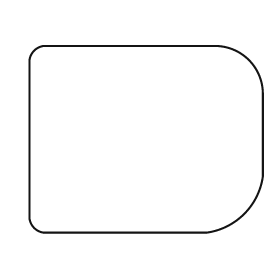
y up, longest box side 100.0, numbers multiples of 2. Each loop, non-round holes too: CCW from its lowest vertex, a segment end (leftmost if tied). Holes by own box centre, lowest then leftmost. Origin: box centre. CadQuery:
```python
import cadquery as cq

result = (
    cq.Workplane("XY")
    .moveTo(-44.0, -40.0)
    .lineTo(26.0, -40.0)
    .threePointArc((42.0, -32.0), (50.0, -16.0))
    .lineTo(50.0, 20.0)
    .threePointArc((44.0, 34.0), (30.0, 40.0))
    .lineTo(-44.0, 40.0)
    .threePointArc((-48.0, 38.0), (-50.0, 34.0))
    .lineTo(-50.0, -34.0)
    .threePointArc((-48.0, -38.0), (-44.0, -40.0))
    .close()
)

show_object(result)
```